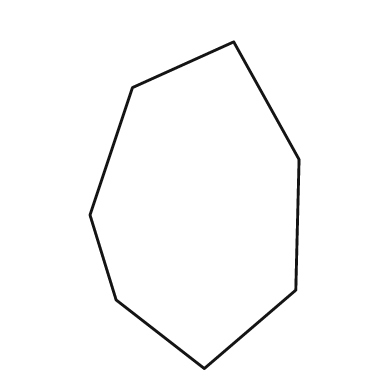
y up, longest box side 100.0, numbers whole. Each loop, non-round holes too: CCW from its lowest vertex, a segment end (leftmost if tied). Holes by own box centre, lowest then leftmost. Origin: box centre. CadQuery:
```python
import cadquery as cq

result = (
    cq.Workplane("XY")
    .moveTo(3.0, -50.0)
    .lineTo(31.0, -26.0)
    .lineTo(32.0, 14.0)
    .lineTo(12.0, 50.0)
    .lineTo(-19.0, 36.0)
    .lineTo(-32.0, -3.0)
    .lineTo(-24.0, -29.0)
    .close()
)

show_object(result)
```